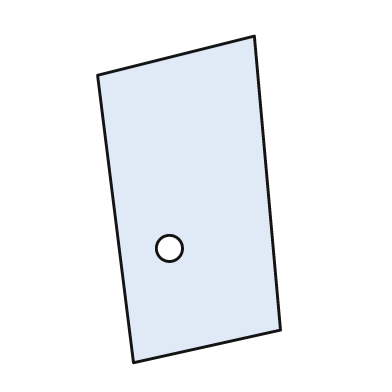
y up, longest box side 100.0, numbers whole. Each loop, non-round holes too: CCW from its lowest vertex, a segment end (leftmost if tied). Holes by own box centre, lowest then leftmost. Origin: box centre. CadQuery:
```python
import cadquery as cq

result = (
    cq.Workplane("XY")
    .moveTo(-17.0, -50.0)
    .lineTo(28.0, -40.0)
    .lineTo(20.0, 50.0)
    .lineTo(-28.0, 38.0)
    .close()
    .moveTo(-6.0, -15.0)
    .circle(4.0)
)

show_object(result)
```